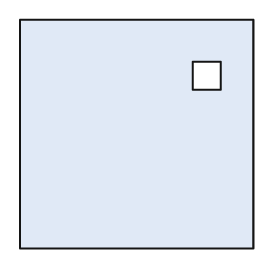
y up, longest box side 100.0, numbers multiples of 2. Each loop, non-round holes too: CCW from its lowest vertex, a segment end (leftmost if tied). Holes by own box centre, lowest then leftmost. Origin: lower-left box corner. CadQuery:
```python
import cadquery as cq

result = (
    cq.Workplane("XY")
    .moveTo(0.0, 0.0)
    .lineTo(100.0, 0.0)
    .lineTo(100.0, 98.0)
    .lineTo(0.0, 98.0)
    .close()
    .moveTo(74.0, 68.0)
    .lineTo(86.0, 68.0)
    .lineTo(86.0, 80.0)
    .lineTo(74.0, 80.0)
    .close()
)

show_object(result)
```